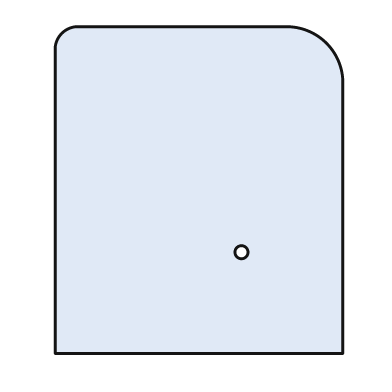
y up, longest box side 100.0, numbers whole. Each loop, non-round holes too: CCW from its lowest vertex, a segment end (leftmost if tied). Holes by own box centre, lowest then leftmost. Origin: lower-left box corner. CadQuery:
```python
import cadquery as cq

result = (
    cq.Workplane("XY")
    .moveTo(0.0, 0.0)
    .lineTo(88.0, 0.0)
    .lineTo(88.0, 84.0)
    .threePointArc((83.0, 95.0), (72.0, 100.0))
    .lineTo(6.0, 100.0)
    .threePointArc((2.0, 98.0), (0.0, 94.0))
    .close()
    .moveTo(57.0, 31.0)
    .circle(2.0)
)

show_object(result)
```